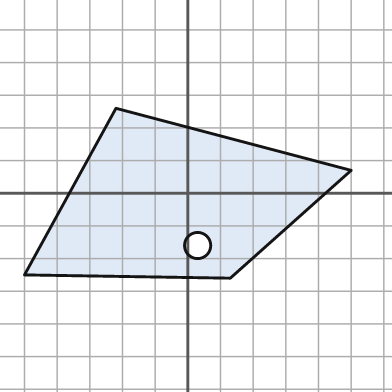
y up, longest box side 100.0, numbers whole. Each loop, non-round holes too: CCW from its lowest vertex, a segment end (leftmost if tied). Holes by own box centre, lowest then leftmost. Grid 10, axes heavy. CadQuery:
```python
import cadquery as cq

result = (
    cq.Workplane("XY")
    .moveTo(13.0, -26.0)
    .lineTo(50.0, 7.0)
    .lineTo(-22.0, 26.0)
    .lineTo(-50.0, -25.0)
    .close()
    .moveTo(3.0, -16.0)
    .circle(4.0)
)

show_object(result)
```